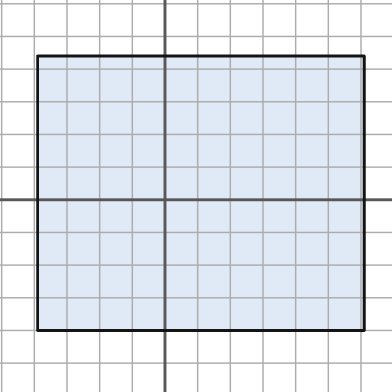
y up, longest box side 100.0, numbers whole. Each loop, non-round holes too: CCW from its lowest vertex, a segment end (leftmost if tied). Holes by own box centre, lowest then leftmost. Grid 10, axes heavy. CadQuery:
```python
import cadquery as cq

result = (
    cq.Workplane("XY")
    .moveTo(-39.0, -40.0)
    .lineTo(61.0, -40.0)
    .lineTo(61.0, 44.0)
    .lineTo(-39.0, 44.0)
    .close()
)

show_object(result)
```